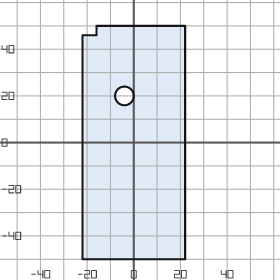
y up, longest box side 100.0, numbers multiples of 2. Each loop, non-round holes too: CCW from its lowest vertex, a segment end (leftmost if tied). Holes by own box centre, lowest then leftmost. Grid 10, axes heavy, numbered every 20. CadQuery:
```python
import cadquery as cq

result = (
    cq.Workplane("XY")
    .moveTo(-22.0, -50.0)
    .lineTo(22.0, -50.0)
    .lineTo(22.0, 50.0)
    .lineTo(-16.0, 50.0)
    .lineTo(-16.0, 46.0)
    .lineTo(-22.0, 46.0)
    .close()
    .moveTo(-4.0, 20.0)
    .circle(4.0)
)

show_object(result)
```